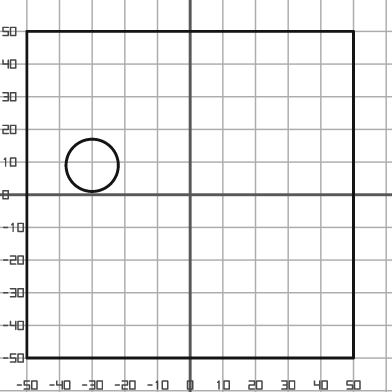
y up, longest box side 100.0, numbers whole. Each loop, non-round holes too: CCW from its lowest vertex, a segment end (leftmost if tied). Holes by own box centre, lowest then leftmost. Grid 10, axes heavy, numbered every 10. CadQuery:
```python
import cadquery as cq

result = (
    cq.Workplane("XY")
    .moveTo(-50.0, -50.0)
    .lineTo(50.0, -50.0)
    .lineTo(50.0, 50.0)
    .lineTo(-50.0, 50.0)
    .close()
    .moveTo(-30.0, 9.0)
    .circle(8.0)
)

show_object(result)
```